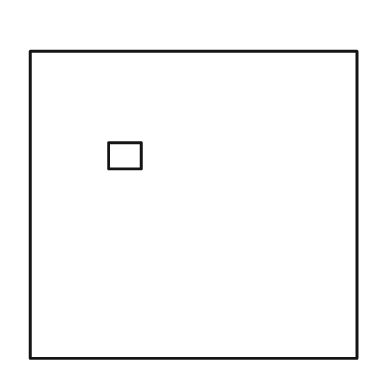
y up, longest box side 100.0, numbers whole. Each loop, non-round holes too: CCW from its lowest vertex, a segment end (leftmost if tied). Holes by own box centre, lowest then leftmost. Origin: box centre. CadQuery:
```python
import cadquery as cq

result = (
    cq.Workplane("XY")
    .moveTo(-50.0, -47.0)
    .lineTo(50.0, -47.0)
    .lineTo(50.0, 47.0)
    .lineTo(-50.0, 47.0)
    .close()
    .moveTo(-26.0, 11.0)
    .lineTo(-16.0, 11.0)
    .lineTo(-16.0, 19.0)
    .lineTo(-26.0, 19.0)
    .close()
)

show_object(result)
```